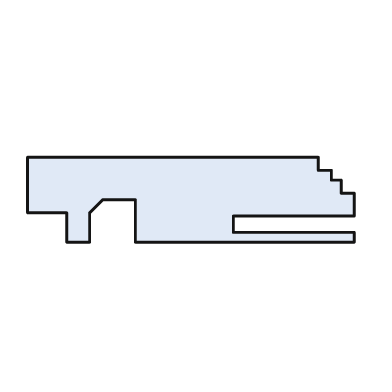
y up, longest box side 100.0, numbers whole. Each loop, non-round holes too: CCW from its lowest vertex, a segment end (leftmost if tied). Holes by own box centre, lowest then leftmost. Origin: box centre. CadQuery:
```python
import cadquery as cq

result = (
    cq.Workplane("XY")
    .moveTo(-38.0, -13.0)
    .lineTo(-31.0, -13.0)
    .lineTo(-31.0, -4.0)
    .lineTo(-27.0, 0.0)
    .lineTo(-17.0, 0.0)
    .lineTo(-17.0, -13.0)
    .lineTo(50.0, -13.0)
    .lineTo(50.0, -10.0)
    .lineTo(13.0, -10.0)
    .lineTo(13.0, -5.0)
    .lineTo(50.0, -5.0)
    .lineTo(50.0, 2.0)
    .lineTo(46.0, 2.0)
    .lineTo(46.0, 6.0)
    .lineTo(43.0, 6.0)
    .lineTo(43.0, 9.0)
    .lineTo(39.0, 9.0)
    .lineTo(39.0, 13.0)
    .lineTo(-50.0, 13.0)
    .lineTo(-50.0, -4.0)
    .lineTo(-38.0, -4.0)
    .close()
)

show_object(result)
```